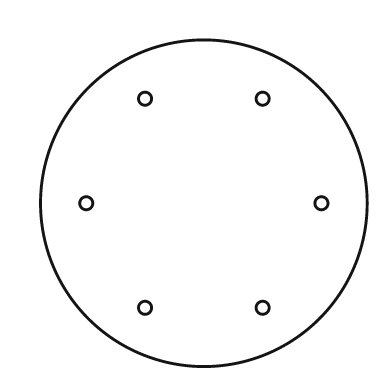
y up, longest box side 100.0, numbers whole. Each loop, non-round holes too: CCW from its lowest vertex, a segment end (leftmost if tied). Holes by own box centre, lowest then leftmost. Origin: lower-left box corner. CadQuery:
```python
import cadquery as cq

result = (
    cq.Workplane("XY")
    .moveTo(50.0, 50.0)
    .circle(50.0)
    .moveTo(32.0, 18.0)
    .circle(2.0)
    .moveTo(68.0, 18.0)
    .circle(2.0)
    .moveTo(14.0, 50.0)
    .circle(2.0)
    .moveTo(86.0, 50.0)
    .circle(2.0)
    .moveTo(32.0, 82.0)
    .circle(2.0)
    .moveTo(68.0, 82.0)
    .circle(2.0)
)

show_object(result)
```